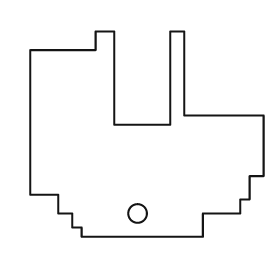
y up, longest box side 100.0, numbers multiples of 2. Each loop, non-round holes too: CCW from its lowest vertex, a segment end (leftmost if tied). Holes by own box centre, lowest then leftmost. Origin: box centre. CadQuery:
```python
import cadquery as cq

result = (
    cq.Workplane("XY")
    .moveTo(-28.0, -44.0)
    .lineTo(24.0, -44.0)
    .lineTo(24.0, -34.0)
    .lineTo(40.0, -34.0)
    .lineTo(40.0, -28.0)
    .lineTo(44.0, -28.0)
    .lineTo(44.0, -18.0)
    .lineTo(50.0, -18.0)
    .lineTo(50.0, 8.0)
    .lineTo(16.0, 8.0)
    .lineTo(16.0, 44.0)
    .lineTo(10.0, 44.0)
    .lineTo(10.0, 4.0)
    .lineTo(-14.0, 4.0)
    .lineTo(-14.0, 44.0)
    .lineTo(-22.0, 44.0)
    .lineTo(-22.0, 36.0)
    .lineTo(-50.0, 36.0)
    .lineTo(-50.0, -26.0)
    .lineTo(-38.0, -26.0)
    .lineTo(-38.0, -34.0)
    .lineTo(-32.0, -34.0)
    .lineTo(-32.0, -40.0)
    .lineTo(-28.0, -40.0)
    .close()
    .moveTo(-4.0, -34.0)
    .circle(4.0)
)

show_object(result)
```